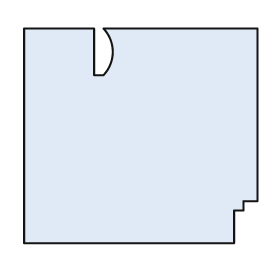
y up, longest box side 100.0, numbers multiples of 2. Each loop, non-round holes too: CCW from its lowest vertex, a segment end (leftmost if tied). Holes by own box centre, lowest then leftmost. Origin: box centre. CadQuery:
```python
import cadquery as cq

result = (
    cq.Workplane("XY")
    .moveTo(-50.0, -46.0)
    .lineTo(40.0, -46.0)
    .lineTo(40.0, -32.0)
    .lineTo(44.0, -32.0)
    .lineTo(44.0, -28.0)
    .lineTo(50.0, -28.0)
    .lineTo(50.0, 46.0)
    .lineTo(-16.0, 46.0)
    .threePointArc((-12.0, 36.0), (-16.0, 26.0))
    .lineTo(-20.0, 26.0)
    .lineTo(-20.0, 46.0)
    .lineTo(-50.0, 46.0)
    .close()
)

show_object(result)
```